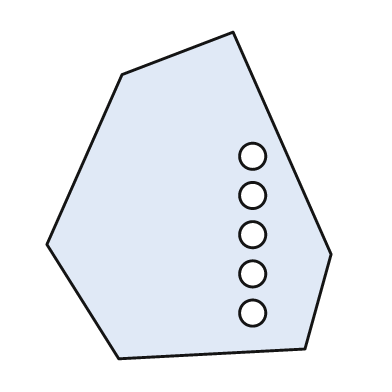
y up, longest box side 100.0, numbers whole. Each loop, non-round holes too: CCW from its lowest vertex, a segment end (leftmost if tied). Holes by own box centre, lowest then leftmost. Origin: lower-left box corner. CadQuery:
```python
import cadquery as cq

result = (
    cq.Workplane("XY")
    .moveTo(22.0, 0.0)
    .lineTo(79.0, 3.0)
    .lineTo(87.0, 32.0)
    .lineTo(57.0, 100.0)
    .lineTo(23.0, 87.0)
    .lineTo(0.0, 35.0)
    .close()
    .moveTo(63.0, 14.0)
    .circle(4.0)
    .moveTo(63.0, 26.0)
    .circle(4.0)
    .moveTo(63.0, 38.0)
    .circle(4.0)
    .moveTo(63.0, 50.0)
    .circle(4.0)
    .moveTo(63.0, 62.0)
    .circle(4.0)
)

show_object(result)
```